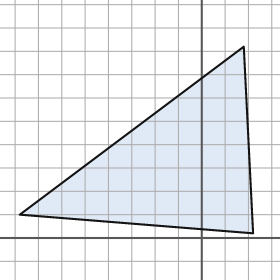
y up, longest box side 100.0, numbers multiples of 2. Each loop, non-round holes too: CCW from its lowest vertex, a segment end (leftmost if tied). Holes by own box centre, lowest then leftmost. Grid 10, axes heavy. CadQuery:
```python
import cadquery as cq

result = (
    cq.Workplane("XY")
    .moveTo(22.0, 2.0)
    .lineTo(18.0, 82.0)
    .lineTo(-78.0, 10.0)
    .close()
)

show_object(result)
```